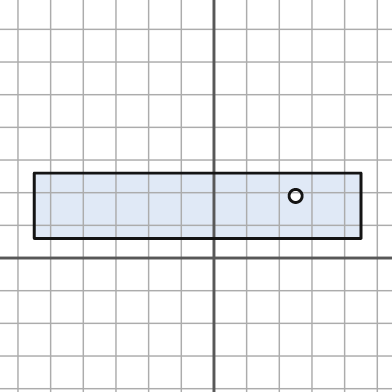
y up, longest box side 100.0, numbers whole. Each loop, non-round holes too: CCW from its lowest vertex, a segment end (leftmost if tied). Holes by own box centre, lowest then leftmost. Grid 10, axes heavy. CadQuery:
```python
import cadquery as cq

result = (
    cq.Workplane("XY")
    .moveTo(-55.0, 6.0)
    .lineTo(45.0, 6.0)
    .lineTo(45.0, 26.0)
    .lineTo(-55.0, 26.0)
    .close()
    .moveTo(25.0, 19.0)
    .circle(2.0)
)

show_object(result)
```